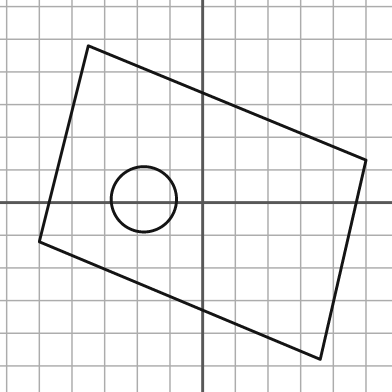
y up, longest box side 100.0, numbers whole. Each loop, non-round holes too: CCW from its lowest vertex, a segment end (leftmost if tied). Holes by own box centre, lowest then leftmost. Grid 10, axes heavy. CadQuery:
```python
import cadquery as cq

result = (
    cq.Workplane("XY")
    .moveTo(36.0, -48.0)
    .lineTo(50.0, 13.0)
    .lineTo(-35.0, 48.0)
    .lineTo(-50.0, -12.0)
    .close()
    .moveTo(-18.0, 1.0)
    .circle(10.0)
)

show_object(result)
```